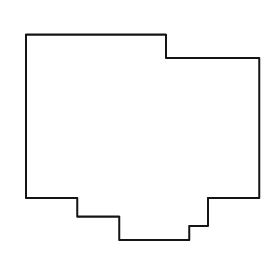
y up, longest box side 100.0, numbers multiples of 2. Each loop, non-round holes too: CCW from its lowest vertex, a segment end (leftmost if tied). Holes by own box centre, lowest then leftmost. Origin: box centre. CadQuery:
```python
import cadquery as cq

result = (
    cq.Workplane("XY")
    .moveTo(-10.0, -44.0)
    .lineTo(20.0, -44.0)
    .lineTo(20.0, -38.0)
    .lineTo(28.0, -38.0)
    .lineTo(28.0, -26.0)
    .lineTo(50.0, -26.0)
    .lineTo(50.0, 34.0)
    .lineTo(10.0, 34.0)
    .lineTo(10.0, 44.0)
    .lineTo(-50.0, 44.0)
    .lineTo(-50.0, -26.0)
    .lineTo(-28.0, -26.0)
    .lineTo(-28.0, -34.0)
    .lineTo(-10.0, -34.0)
    .close()
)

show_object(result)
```